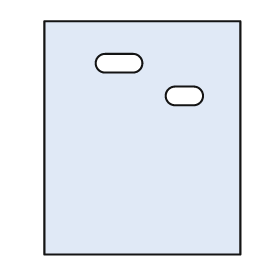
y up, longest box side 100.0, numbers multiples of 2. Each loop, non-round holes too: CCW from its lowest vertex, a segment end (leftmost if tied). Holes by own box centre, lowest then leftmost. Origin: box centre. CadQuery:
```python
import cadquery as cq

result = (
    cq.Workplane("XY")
    .moveTo(-42.0, -50.0)
    .lineTo(42.0, -50.0)
    .lineTo(42.0, 50.0)
    .lineTo(-42.0, 50.0)
    .close()
    .moveTo(14.0, 14.0)
    .lineTo(22.0, 14.0)
    .threePointArc((26.0, 18.0), (22.0, 22.0))
    .lineTo(14.0, 22.0)
    .threePointArc((10.0, 18.0), (14.0, 14.0))
    .close()
    .moveTo(-16.0, 28.0)
    .lineTo(-4.0, 28.0)
    .threePointArc((0.0, 32.0), (-4.0, 36.0))
    .lineTo(-16.0, 36.0)
    .threePointArc((-20.0, 32.0), (-16.0, 28.0))
    .close()
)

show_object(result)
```